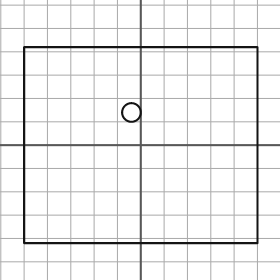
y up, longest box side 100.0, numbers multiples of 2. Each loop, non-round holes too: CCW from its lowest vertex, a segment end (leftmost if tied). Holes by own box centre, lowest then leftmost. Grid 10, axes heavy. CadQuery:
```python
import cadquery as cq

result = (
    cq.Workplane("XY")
    .moveTo(-50.0, -42.0)
    .lineTo(50.0, -42.0)
    .lineTo(50.0, 42.0)
    .lineTo(-50.0, 42.0)
    .close()
    .moveTo(-4.0, 14.0)
    .circle(4.0)
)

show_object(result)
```